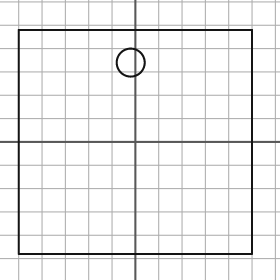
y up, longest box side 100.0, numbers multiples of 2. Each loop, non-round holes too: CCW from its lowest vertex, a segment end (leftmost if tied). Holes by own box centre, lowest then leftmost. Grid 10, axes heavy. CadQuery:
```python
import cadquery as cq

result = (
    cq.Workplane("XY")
    .moveTo(-50.0, -48.0)
    .lineTo(50.0, -48.0)
    .lineTo(50.0, 48.0)
    .lineTo(-50.0, 48.0)
    .close()
    .moveTo(-2.0, 34.0)
    .circle(6.0)
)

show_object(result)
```